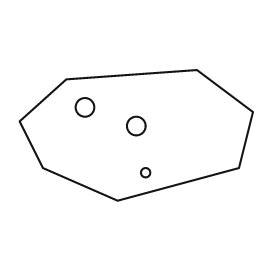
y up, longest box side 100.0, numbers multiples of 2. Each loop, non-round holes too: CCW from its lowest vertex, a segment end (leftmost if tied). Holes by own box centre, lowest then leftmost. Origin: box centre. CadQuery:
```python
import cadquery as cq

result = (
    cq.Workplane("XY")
    .moveTo(-8.0, -28.0)
    .lineTo(44.0, -14.0)
    .lineTo(50.0, 10.0)
    .lineTo(26.0, 28.0)
    .lineTo(-30.0, 24.0)
    .lineTo(-50.0, 6.0)
    .lineTo(-40.0, -14.0)
    .close()
    .moveTo(4.0, -16.0)
    .circle(2.0)
    .moveTo(0.0, 4.0)
    .circle(4.0)
    .moveTo(-22.0, 12.0)
    .circle(4.0)
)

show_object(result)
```